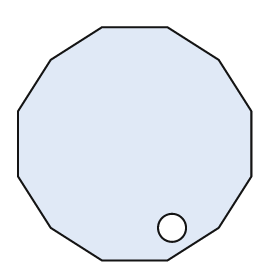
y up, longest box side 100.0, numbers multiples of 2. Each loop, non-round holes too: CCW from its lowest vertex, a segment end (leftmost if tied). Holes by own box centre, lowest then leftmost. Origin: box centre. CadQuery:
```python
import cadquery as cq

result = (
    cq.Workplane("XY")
    .moveTo(-14.0, -50.0)
    .lineTo(14.0, -50.0)
    .lineTo(36.0, -36.0)
    .lineTo(50.0, -14.0)
    .lineTo(50.0, 14.0)
    .lineTo(36.0, 36.0)
    .lineTo(14.0, 50.0)
    .lineTo(-14.0, 50.0)
    .lineTo(-36.0, 36.0)
    .lineTo(-50.0, 14.0)
    .lineTo(-50.0, -14.0)
    .lineTo(-36.0, -36.0)
    .close()
    .moveTo(16.0, -36.0)
    .circle(6.0)
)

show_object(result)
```